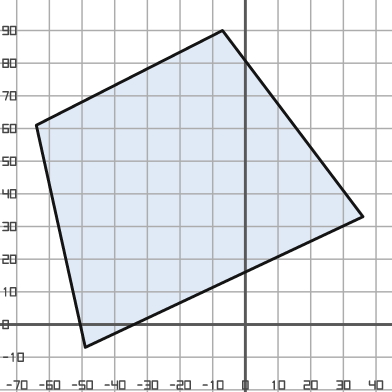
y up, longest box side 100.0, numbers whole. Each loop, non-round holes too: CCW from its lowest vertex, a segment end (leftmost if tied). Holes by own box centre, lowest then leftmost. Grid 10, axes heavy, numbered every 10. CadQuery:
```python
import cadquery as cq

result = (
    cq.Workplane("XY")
    .moveTo(-49.0, -7.0)
    .lineTo(36.0, 33.0)
    .lineTo(-7.0, 90.0)
    .lineTo(-64.0, 61.0)
    .close()
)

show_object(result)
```